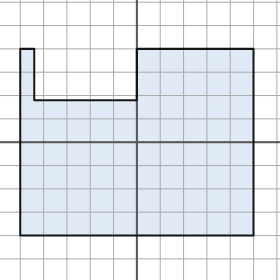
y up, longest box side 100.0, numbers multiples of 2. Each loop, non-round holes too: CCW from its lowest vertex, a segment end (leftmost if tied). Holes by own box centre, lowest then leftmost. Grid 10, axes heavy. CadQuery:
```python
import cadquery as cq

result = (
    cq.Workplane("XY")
    .moveTo(-50.0, -40.0)
    .lineTo(50.0, -40.0)
    .lineTo(50.0, 40.0)
    .lineTo(0.0, 40.0)
    .lineTo(0.0, 18.0)
    .lineTo(-44.0, 18.0)
    .lineTo(-44.0, 40.0)
    .lineTo(-50.0, 40.0)
    .close()
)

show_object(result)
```